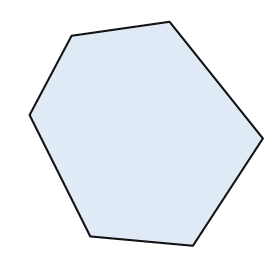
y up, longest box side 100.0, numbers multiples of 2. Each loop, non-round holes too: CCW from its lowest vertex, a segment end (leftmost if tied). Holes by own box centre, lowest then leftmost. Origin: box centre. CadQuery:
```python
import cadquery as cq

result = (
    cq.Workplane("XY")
    .moveTo(20.0, -48.0)
    .lineTo(50.0, -2.0)
    .lineTo(10.0, 48.0)
    .lineTo(-32.0, 42.0)
    .lineTo(-50.0, 8.0)
    .lineTo(-24.0, -44.0)
    .close()
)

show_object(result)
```